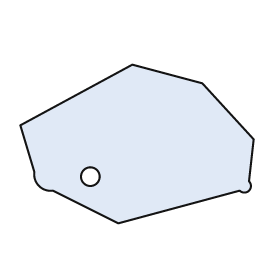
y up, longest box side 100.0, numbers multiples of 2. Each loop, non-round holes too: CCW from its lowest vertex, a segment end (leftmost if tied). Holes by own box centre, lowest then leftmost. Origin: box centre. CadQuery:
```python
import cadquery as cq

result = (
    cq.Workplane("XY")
    .moveTo(-8.0, -34.0)
    .lineTo(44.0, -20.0)
    .threePointArc((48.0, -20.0), (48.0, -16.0))
    .lineTo(50.0, 2.0)
    .lineTo(28.0, 26.0)
    .lineTo(-2.0, 34.0)
    .lineTo(-50.0, 8.0)
    .lineTo(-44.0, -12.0)
    .threePointArc((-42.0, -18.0), (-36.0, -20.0))
    .close()
    .moveTo(-20.0, -14.0)
    .circle(4.0)
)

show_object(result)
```